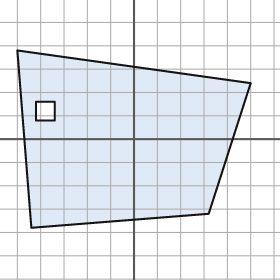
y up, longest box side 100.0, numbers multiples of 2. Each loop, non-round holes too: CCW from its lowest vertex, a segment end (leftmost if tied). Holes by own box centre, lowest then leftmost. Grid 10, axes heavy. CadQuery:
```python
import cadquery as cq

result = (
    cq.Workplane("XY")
    .moveTo(-44.0, -38.0)
    .lineTo(32.0, -32.0)
    .lineTo(50.0, 24.0)
    .lineTo(-50.0, 38.0)
    .close()
    .moveTo(-42.0, 8.0)
    .lineTo(-34.0, 8.0)
    .lineTo(-34.0, 16.0)
    .lineTo(-42.0, 16.0)
    .close()
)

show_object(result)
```